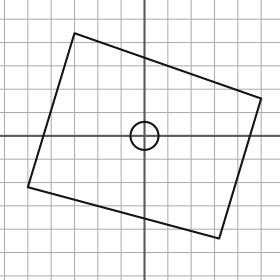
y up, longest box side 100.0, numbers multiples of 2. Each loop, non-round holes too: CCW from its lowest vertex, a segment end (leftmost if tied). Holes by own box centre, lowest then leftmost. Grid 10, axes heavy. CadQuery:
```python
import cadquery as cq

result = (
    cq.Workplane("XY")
    .moveTo(32.0, -44.0)
    .lineTo(50.0, 16.0)
    .lineTo(-30.0, 44.0)
    .lineTo(-50.0, -22.0)
    .close()
    .moveTo(0.0, 0.0)
    .circle(6.0)
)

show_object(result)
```